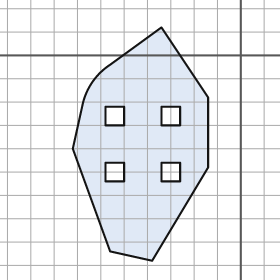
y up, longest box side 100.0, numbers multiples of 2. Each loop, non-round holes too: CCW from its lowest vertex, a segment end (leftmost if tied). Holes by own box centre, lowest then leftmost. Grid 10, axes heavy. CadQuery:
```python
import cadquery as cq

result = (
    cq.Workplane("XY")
    .moveTo(-38.0, -88.0)
    .lineTo(-14.0, -48.0)
    .lineTo(-14.0, -18.0)
    .lineTo(-34.0, 12.0)
    .lineTo(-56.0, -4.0)
    .threePointArc((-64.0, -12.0), (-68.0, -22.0))
    .lineTo(-72.0, -40.0)
    .lineTo(-56.0, -84.0)
    .close()
    .moveTo(-58.0, -54.0)
    .lineTo(-50.0, -54.0)
    .lineTo(-50.0, -46.0)
    .lineTo(-58.0, -46.0)
    .close()
    .moveTo(-34.0, -54.0)
    .lineTo(-26.0, -54.0)
    .lineTo(-26.0, -46.0)
    .lineTo(-34.0, -46.0)
    .close()
    .moveTo(-58.0, -30.0)
    .lineTo(-50.0, -30.0)
    .lineTo(-50.0, -22.0)
    .lineTo(-58.0, -22.0)
    .close()
    .moveTo(-34.0, -30.0)
    .lineTo(-26.0, -30.0)
    .lineTo(-26.0, -22.0)
    .lineTo(-34.0, -22.0)
    .close()
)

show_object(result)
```